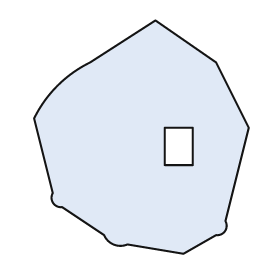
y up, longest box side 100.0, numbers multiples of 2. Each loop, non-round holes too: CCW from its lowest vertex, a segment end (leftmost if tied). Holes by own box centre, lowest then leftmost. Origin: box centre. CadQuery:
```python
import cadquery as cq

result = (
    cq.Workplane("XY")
    .moveTo(18.0, -50.0)
    .lineTo(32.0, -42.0)
    .threePointArc((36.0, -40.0), (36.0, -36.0))
    .lineTo(46.0, 4.0)
    .lineTo(32.0, 32.0)
    .lineTo(6.0, 50.0)
    .lineTo(-22.0, 32.0)
    .threePointArc((-36.0, 22.0), (-46.0, 8.0))
    .lineTo(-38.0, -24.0)
    .threePointArc((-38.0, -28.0), (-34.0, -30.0))
    .lineTo(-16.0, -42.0)
    .threePointArc((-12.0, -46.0), (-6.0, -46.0))
    .close()
    .moveTo(10.0, -12.0)
    .lineTo(22.0, -12.0)
    .lineTo(22.0, 4.0)
    .lineTo(10.0, 4.0)
    .close()
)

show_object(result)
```